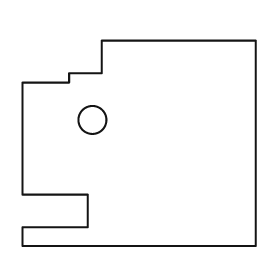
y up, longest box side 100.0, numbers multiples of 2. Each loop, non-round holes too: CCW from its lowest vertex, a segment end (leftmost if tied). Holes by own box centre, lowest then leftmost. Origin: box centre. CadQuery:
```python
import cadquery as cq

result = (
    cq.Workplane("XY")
    .moveTo(-50.0, -44.0)
    .lineTo(50.0, -44.0)
    .lineTo(50.0, 44.0)
    .lineTo(-16.0, 44.0)
    .lineTo(-16.0, 30.0)
    .lineTo(-30.0, 30.0)
    .lineTo(-30.0, 26.0)
    .lineTo(-50.0, 26.0)
    .lineTo(-50.0, -22.0)
    .lineTo(-22.0, -22.0)
    .lineTo(-22.0, -36.0)
    .lineTo(-50.0, -36.0)
    .close()
    .moveTo(-20.0, 10.0)
    .circle(6.0)
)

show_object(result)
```